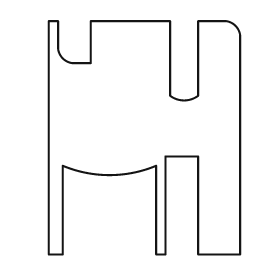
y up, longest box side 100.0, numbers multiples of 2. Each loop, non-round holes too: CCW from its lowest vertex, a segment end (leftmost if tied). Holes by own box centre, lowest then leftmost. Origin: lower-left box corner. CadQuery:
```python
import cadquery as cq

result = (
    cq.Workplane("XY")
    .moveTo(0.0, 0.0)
    .lineTo(6.0, 0.0)
    .lineTo(6.0, 38.0)
    .threePointArc((26.0, 34.0), (46.0, 38.0))
    .lineTo(46.0, 0.0)
    .lineTo(50.0, 0.0)
    .lineTo(50.0, 42.0)
    .lineTo(64.0, 42.0)
    .lineTo(64.0, 0.0)
    .lineTo(82.0, 0.0)
    .lineTo(82.0, 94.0)
    .threePointArc((80.0, 98.0), (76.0, 100.0))
    .lineTo(64.0, 100.0)
    .lineTo(64.0, 68.0)
    .threePointArc((58.0, 66.0), (52.0, 68.0))
    .lineTo(52.0, 100.0)
    .lineTo(18.0, 100.0)
    .lineTo(18.0, 82.0)
    .lineTo(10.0, 82.0)
    .threePointArc((6.0, 84.0), (4.0, 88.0))
    .lineTo(4.0, 100.0)
    .lineTo(0.0, 100.0)
    .close()
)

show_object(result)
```